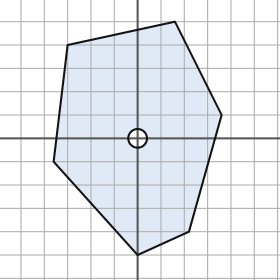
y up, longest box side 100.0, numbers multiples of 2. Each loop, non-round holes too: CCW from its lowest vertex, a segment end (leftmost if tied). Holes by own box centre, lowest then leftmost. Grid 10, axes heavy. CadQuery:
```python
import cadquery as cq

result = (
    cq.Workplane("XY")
    .moveTo(0.0, -50.0)
    .lineTo(22.0, -40.0)
    .lineTo(36.0, 10.0)
    .lineTo(16.0, 50.0)
    .lineTo(-30.0, 40.0)
    .lineTo(-36.0, -10.0)
    .close()
    .moveTo(0.0, 0.0)
    .circle(4.0)
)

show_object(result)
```